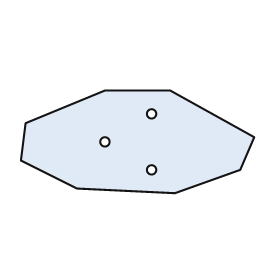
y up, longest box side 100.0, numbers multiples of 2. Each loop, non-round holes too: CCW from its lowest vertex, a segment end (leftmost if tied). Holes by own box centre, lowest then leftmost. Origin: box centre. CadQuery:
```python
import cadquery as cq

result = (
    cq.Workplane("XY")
    .moveTo(16.0, -22.0)
    .lineTo(44.0, -12.0)
    .lineTo(50.0, 2.0)
    .lineTo(14.0, 22.0)
    .lineTo(-14.0, 22.0)
    .lineTo(-48.0, 8.0)
    .lineTo(-50.0, -8.0)
    .lineTo(-26.0, -20.0)
    .close()
    .moveTo(6.0, -12.0)
    .circle(2.0)
    .moveTo(-14.0, 0.0)
    .circle(2.0)
    .moveTo(6.0, 12.0)
    .circle(2.0)
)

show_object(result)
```